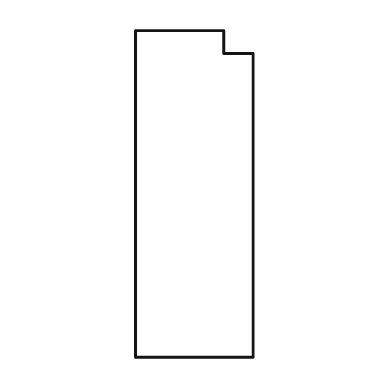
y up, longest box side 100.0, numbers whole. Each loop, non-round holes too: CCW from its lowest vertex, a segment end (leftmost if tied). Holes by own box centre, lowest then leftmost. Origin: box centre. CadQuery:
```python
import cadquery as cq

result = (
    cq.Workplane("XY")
    .moveTo(-18.0, -50.0)
    .lineTo(18.0, -50.0)
    .lineTo(18.0, 43.0)
    .lineTo(9.0, 43.0)
    .lineTo(9.0, 50.0)
    .lineTo(-18.0, 50.0)
    .close()
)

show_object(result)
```